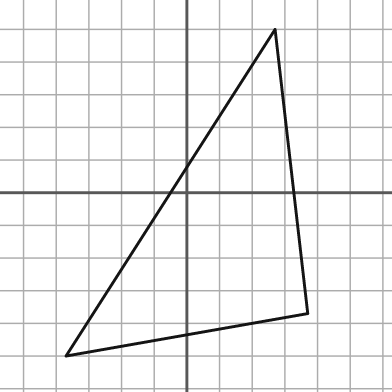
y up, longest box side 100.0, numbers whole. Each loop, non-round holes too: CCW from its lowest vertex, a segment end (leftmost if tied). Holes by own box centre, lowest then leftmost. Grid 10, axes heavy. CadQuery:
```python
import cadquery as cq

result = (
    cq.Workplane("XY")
    .moveTo(-37.0, -50.0)
    .lineTo(37.0, -37.0)
    .lineTo(27.0, 50.0)
    .close()
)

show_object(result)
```